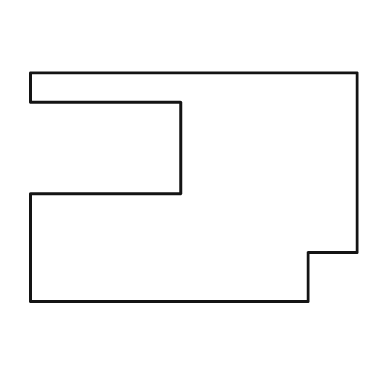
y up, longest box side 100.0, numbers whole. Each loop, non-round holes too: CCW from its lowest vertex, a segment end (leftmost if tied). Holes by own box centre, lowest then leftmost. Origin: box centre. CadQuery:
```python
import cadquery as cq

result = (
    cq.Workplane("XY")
    .moveTo(-50.0, -35.0)
    .lineTo(35.0, -35.0)
    .lineTo(35.0, -20.0)
    .lineTo(50.0, -20.0)
    .lineTo(50.0, 35.0)
    .lineTo(-50.0, 35.0)
    .lineTo(-50.0, 26.0)
    .lineTo(-4.0, 26.0)
    .lineTo(-4.0, -2.0)
    .lineTo(-50.0, -2.0)
    .close()
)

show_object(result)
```